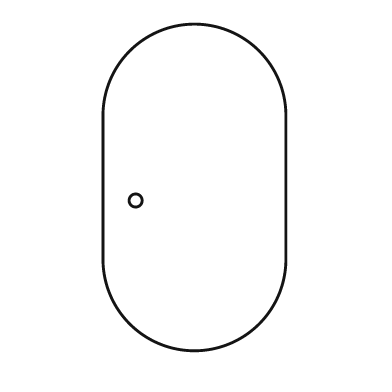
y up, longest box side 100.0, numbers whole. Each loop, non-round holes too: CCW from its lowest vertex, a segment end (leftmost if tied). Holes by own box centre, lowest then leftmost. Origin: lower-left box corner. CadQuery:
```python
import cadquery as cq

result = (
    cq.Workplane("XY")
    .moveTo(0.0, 28.0)
    .threePointArc((28.0, 0.0), (56.0, 28.0))
    .lineTo(56.0, 72.0)
    .threePointArc((28.0, 100.0), (0.0, 72.0))
    .close()
    .moveTo(10.0, 46.0)
    .circle(2.0)
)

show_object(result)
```